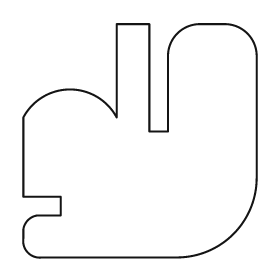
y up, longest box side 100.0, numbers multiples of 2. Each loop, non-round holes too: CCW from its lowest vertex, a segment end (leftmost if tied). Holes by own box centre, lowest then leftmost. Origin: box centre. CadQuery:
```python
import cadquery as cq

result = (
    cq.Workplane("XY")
    .moveTo(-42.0, -50.0)
    .lineTo(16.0, -50.0)
    .threePointArc((40.0, -40.0), (50.0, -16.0))
    .lineTo(50.0, 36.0)
    .threePointArc((46.0, 46.0), (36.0, 50.0))
    .lineTo(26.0, 50.0)
    .threePointArc((16.0, 46.0), (12.0, 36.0))
    .lineTo(12.0, 4.0)
    .lineTo(4.0, 4.0)
    .lineTo(4.0, 50.0)
    .lineTo(-10.0, 50.0)
    .lineTo(-10.0, 10.0)
    .threePointArc((-30.0, 22.0), (-50.0, 10.0))
    .lineTo(-50.0, -24.0)
    .lineTo(-34.0, -24.0)
    .lineTo(-34.0, -32.0)
    .lineTo(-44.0, -32.0)
    .threePointArc((-48.0, -34.0), (-50.0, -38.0))
    .lineTo(-50.0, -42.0)
    .threePointArc((-48.0, -48.0), (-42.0, -50.0))
    .close()
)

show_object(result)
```